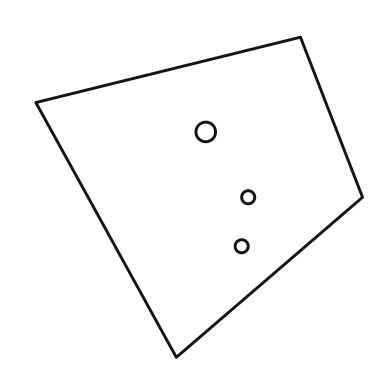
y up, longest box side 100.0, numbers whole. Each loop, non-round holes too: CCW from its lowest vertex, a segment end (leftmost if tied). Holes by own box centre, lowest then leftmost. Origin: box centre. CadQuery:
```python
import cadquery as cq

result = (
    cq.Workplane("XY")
    .moveTo(-7.0, -49.0)
    .lineTo(50.0, 0.0)
    .lineTo(31.0, 49.0)
    .lineTo(-50.0, 29.0)
    .close()
    .moveTo(13.0, -15.0)
    .circle(2.0)
    .moveTo(15.0, 0.0)
    .circle(2.0)
    .moveTo(2.0, 20.0)
    .circle(3.0)
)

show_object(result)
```